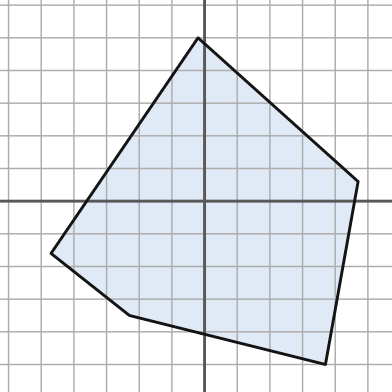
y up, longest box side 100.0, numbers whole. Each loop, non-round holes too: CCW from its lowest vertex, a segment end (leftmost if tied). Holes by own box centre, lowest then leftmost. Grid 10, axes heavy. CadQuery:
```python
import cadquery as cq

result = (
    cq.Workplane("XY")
    .moveTo(37.0, -50.0)
    .lineTo(47.0, 6.0)
    .lineTo(-2.0, 50.0)
    .lineTo(-47.0, -16.0)
    .lineTo(-23.0, -35.0)
    .close()
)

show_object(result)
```